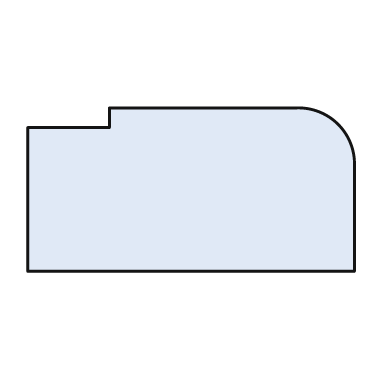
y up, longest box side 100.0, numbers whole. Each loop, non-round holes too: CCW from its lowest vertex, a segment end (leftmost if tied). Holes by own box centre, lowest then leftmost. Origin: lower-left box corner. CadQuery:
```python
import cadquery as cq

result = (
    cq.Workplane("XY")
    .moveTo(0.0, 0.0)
    .lineTo(100.0, 0.0)
    .lineTo(100.0, 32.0)
    .threePointArc((95.0, 45.0), (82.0, 50.0))
    .lineTo(25.0, 50.0)
    .lineTo(25.0, 44.0)
    .lineTo(0.0, 44.0)
    .close()
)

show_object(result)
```